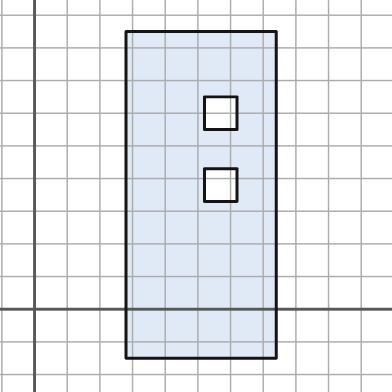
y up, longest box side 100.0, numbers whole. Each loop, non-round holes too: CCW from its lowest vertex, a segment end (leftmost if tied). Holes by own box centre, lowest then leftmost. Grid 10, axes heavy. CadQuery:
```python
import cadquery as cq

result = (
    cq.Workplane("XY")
    .moveTo(28.0, -15.0)
    .lineTo(74.0, -15.0)
    .lineTo(74.0, 85.0)
    .lineTo(28.0, 85.0)
    .close()
    .moveTo(52.0, 33.0)
    .lineTo(62.0, 33.0)
    .lineTo(62.0, 43.0)
    .lineTo(52.0, 43.0)
    .close()
    .moveTo(52.0, 55.0)
    .lineTo(62.0, 55.0)
    .lineTo(62.0, 65.0)
    .lineTo(52.0, 65.0)
    .close()
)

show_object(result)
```